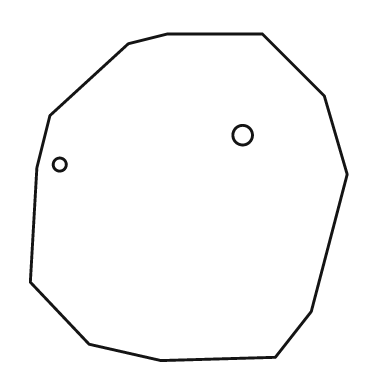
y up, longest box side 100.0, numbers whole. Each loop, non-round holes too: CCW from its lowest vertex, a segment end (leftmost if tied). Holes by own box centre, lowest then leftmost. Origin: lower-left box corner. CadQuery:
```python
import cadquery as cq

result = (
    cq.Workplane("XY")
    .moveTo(40.0, 0.0)
    .lineTo(75.0, 1.0)
    .lineTo(86.0, 15.0)
    .lineTo(97.0, 57.0)
    .lineTo(90.0, 81.0)
    .lineTo(71.0, 100.0)
    .lineTo(42.0, 100.0)
    .lineTo(30.0, 97.0)
    .lineTo(6.0, 75.0)
    .lineTo(2.0, 59.0)
    .lineTo(0.0, 24.0)
    .lineTo(18.0, 5.0)
    .close()
    .moveTo(9.0, 60.0)
    .circle(2.0)
    .moveTo(65.0, 69.0)
    .circle(3.0)
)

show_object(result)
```